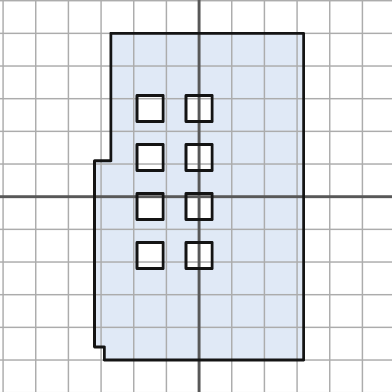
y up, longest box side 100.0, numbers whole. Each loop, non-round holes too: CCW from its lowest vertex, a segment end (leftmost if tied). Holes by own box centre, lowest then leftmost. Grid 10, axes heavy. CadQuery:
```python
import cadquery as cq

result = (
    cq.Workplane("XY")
    .moveTo(-29.0, -50.0)
    .lineTo(32.0, -50.0)
    .lineTo(32.0, 50.0)
    .lineTo(-27.0, 50.0)
    .lineTo(-27.0, 11.0)
    .lineTo(-32.0, 11.0)
    .lineTo(-32.0, -46.0)
    .lineTo(-29.0, -46.0)
    .close()
    .moveTo(-19.0, -22.0)
    .lineTo(-11.0, -22.0)
    .lineTo(-11.0, -14.0)
    .lineTo(-19.0, -14.0)
    .close()
    .moveTo(-4.0, -22.0)
    .lineTo(4.0, -22.0)
    .lineTo(4.0, -14.0)
    .lineTo(-4.0, -14.0)
    .close()
    .moveTo(-19.0, -7.0)
    .lineTo(-11.0, -7.0)
    .lineTo(-11.0, 1.0)
    .lineTo(-19.0, 1.0)
    .close()
    .moveTo(-4.0, -7.0)
    .lineTo(4.0, -7.0)
    .lineTo(4.0, 1.0)
    .lineTo(-4.0, 1.0)
    .close()
    .moveTo(-19.0, 8.0)
    .lineTo(-11.0, 8.0)
    .lineTo(-11.0, 16.0)
    .lineTo(-19.0, 16.0)
    .close()
    .moveTo(-4.0, 8.0)
    .lineTo(4.0, 8.0)
    .lineTo(4.0, 16.0)
    .lineTo(-4.0, 16.0)
    .close()
    .moveTo(-19.0, 23.0)
    .lineTo(-11.0, 23.0)
    .lineTo(-11.0, 31.0)
    .lineTo(-19.0, 31.0)
    .close()
    .moveTo(-4.0, 23.0)
    .lineTo(4.0, 23.0)
    .lineTo(4.0, 31.0)
    .lineTo(-4.0, 31.0)
    .close()
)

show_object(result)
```